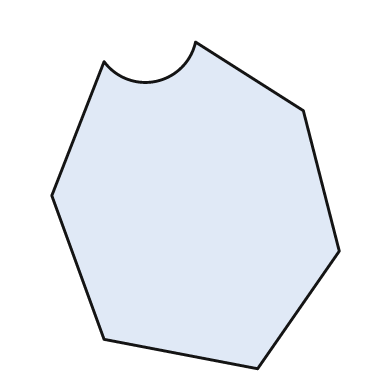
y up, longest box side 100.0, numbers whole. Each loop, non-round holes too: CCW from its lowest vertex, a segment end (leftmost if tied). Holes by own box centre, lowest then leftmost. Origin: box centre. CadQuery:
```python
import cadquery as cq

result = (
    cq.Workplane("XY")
    .moveTo(19.0, -50.0)
    .lineTo(44.0, -14.0)
    .lineTo(33.0, 29.0)
    .lineTo(0.0, 50.0)
    .threePointArc((-12.0, 38.0), (-28.0, 44.0))
    .lineTo(-44.0, 3.0)
    .lineTo(-28.0, -41.0)
    .close()
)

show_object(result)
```